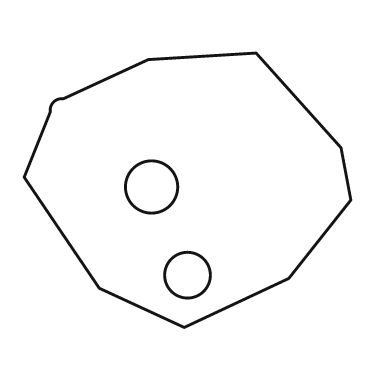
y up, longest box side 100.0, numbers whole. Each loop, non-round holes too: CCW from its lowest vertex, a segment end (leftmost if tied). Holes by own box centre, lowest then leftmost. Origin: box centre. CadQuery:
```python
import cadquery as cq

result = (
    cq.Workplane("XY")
    .moveTo(-1.0, -42.0)
    .lineTo(31.0, -27.0)
    .lineTo(50.0, -3.0)
    .lineTo(47.0, 13.0)
    .lineTo(21.0, 42.0)
    .lineTo(-12.0, 40.0)
    .lineTo(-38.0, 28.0)
    .threePointArc((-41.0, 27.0), (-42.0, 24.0))
    .lineTo(-50.0, 4.0)
    .lineTo(-27.0, -30.0)
    .close()
    .moveTo(0.0, -26.0)
    .circle(7.0)
    .moveTo(-11.0, 1.0)
    .circle(8.0)
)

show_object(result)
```